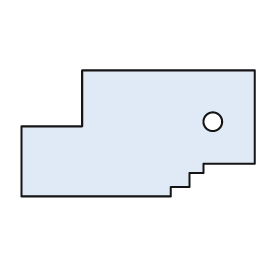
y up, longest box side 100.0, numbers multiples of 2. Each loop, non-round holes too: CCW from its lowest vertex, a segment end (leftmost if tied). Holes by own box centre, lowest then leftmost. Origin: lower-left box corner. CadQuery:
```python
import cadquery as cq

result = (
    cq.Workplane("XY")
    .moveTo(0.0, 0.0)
    .lineTo(64.0, 0.0)
    .lineTo(64.0, 4.0)
    .lineTo(72.0, 4.0)
    .lineTo(72.0, 10.0)
    .lineTo(78.0, 10.0)
    .lineTo(78.0, 14.0)
    .lineTo(100.0, 14.0)
    .lineTo(100.0, 54.0)
    .lineTo(26.0, 54.0)
    .lineTo(26.0, 30.0)
    .lineTo(0.0, 30.0)
    .close()
    .moveTo(82.0, 32.0)
    .circle(4.0)
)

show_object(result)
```